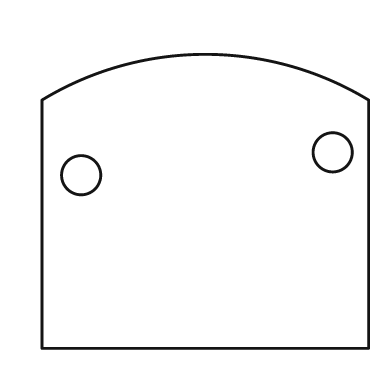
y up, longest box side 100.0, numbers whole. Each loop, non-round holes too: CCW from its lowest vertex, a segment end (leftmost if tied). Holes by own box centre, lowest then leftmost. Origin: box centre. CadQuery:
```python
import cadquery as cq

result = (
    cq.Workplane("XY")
    .moveTo(-50.0, -45.0)
    .lineTo(50.0, -45.0)
    .lineTo(50.0, 31.0)
    .threePointArc((0.0, 45.0), (-50.0, 31.0))
    .close()
    .moveTo(-38.0, 8.0)
    .circle(6.0)
    .moveTo(39.0, 15.0)
    .circle(6.0)
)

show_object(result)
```